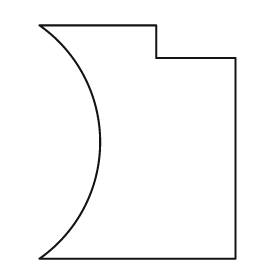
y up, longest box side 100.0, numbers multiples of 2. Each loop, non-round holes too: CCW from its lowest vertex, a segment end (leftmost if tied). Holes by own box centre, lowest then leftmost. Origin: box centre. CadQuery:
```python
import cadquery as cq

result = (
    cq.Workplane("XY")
    .moveTo(-42.0, -50.0)
    .lineTo(42.0, -50.0)
    .lineTo(42.0, 36.0)
    .lineTo(8.0, 36.0)
    .lineTo(8.0, 50.0)
    .lineTo(-42.0, 50.0)
    .threePointArc((-16.0, 0.0), (-42.0, -50.0))
    .close()
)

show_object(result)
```